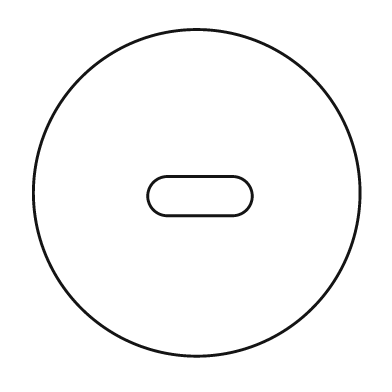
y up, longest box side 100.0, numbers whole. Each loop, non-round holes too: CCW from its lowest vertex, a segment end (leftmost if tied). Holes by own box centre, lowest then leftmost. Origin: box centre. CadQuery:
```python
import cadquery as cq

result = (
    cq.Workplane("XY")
    .moveTo(0.0, 0.0)
    .circle(50.0)
    .moveTo(-9.0, -7.0)
    .lineTo(11.0, -7.0)
    .threePointArc((17.0, -1.0), (11.0, 5.0))
    .lineTo(-9.0, 5.0)
    .threePointArc((-15.0, -1.0), (-9.0, -7.0))
    .close()
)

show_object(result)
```